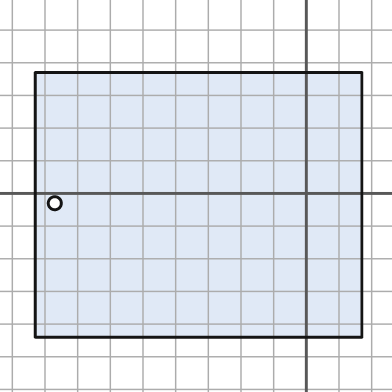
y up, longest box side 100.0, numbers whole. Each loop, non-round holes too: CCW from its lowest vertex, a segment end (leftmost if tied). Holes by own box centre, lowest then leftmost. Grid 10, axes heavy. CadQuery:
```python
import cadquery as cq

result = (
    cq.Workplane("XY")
    .moveTo(-83.0, -44.0)
    .lineTo(17.0, -44.0)
    .lineTo(17.0, 37.0)
    .lineTo(-83.0, 37.0)
    .close()
    .moveTo(-77.0, -3.0)
    .circle(2.0)
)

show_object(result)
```